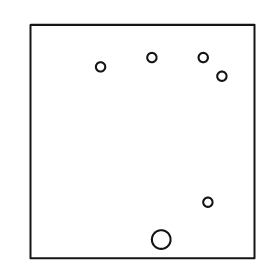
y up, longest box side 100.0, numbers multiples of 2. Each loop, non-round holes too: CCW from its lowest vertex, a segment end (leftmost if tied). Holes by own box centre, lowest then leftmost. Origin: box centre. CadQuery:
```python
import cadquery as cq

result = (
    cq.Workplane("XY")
    .moveTo(-48.0, -50.0)
    .lineTo(48.0, -50.0)
    .lineTo(48.0, 50.0)
    .lineTo(-48.0, 50.0)
    .close()
    .moveTo(8.0, -42.0)
    .circle(4.0)
    .moveTo(28.0, -26.0)
    .circle(2.0)
    .moveTo(34.0, 28.0)
    .circle(2.0)
    .moveTo(-18.0, 32.0)
    .circle(2.0)
    .moveTo(4.0, 36.0)
    .circle(2.0)
    .moveTo(26.0, 36.0)
    .circle(2.0)
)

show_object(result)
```